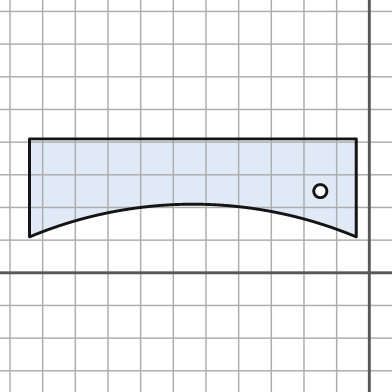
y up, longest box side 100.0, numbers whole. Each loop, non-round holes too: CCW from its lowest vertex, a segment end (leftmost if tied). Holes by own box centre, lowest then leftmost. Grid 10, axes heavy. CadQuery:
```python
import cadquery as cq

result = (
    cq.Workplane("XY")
    .moveTo(-104.0, 11.0)
    .threePointArc((-54.0, 21.0), (-4.0, 11.0))
    .lineTo(-4.0, 41.0)
    .lineTo(-104.0, 41.0)
    .close()
    .moveTo(-15.0, 25.0)
    .circle(2.0)
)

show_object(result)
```